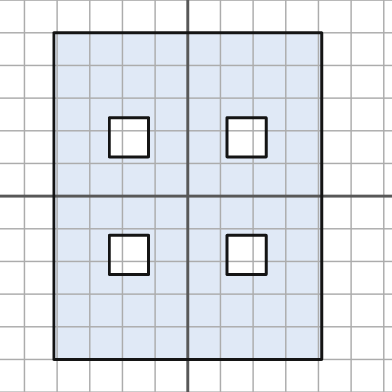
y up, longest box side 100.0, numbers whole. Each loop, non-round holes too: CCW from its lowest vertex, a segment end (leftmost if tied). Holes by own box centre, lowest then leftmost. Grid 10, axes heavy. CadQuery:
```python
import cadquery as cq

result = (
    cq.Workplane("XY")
    .moveTo(-41.0, -50.0)
    .lineTo(41.0, -50.0)
    .lineTo(41.0, 50.0)
    .lineTo(-41.0, 50.0)
    .close()
    .moveTo(-24.0, -24.0)
    .lineTo(-12.0, -24.0)
    .lineTo(-12.0, -12.0)
    .lineTo(-24.0, -12.0)
    .close()
    .moveTo(12.0, -24.0)
    .lineTo(24.0, -24.0)
    .lineTo(24.0, -12.0)
    .lineTo(12.0, -12.0)
    .close()
    .moveTo(-24.0, 12.0)
    .lineTo(-12.0, 12.0)
    .lineTo(-12.0, 24.0)
    .lineTo(-24.0, 24.0)
    .close()
    .moveTo(12.0, 12.0)
    .lineTo(24.0, 12.0)
    .lineTo(24.0, 24.0)
    .lineTo(12.0, 24.0)
    .close()
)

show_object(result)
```